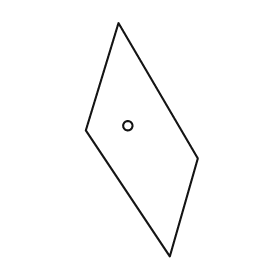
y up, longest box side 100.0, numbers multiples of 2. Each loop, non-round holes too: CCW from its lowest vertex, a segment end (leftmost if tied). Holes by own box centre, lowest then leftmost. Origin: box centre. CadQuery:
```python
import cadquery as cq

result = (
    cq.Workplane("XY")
    .moveTo(12.0, -50.0)
    .lineTo(24.0, -8.0)
    .lineTo(-10.0, 50.0)
    .lineTo(-24.0, 4.0)
    .close()
    .moveTo(-6.0, 6.0)
    .circle(2.0)
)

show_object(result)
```